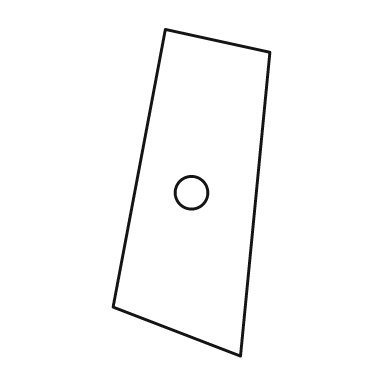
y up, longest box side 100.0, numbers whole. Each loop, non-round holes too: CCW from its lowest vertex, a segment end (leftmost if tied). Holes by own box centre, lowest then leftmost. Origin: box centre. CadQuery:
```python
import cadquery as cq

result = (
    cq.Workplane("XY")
    .moveTo(15.0, -50.0)
    .lineTo(24.0, 43.0)
    .lineTo(-8.0, 50.0)
    .lineTo(-24.0, -35.0)
    .close()
    .moveTo(0.0, 0.0)
    .circle(5.0)
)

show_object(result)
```